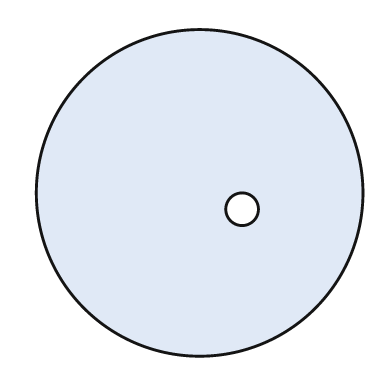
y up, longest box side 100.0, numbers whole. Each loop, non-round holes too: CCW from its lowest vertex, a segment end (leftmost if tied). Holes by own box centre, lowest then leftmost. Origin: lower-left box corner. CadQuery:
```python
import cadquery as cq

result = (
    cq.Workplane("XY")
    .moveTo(50.0, 50.0)
    .circle(50.0)
    .moveTo(63.0, 45.0)
    .circle(5.0)
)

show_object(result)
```